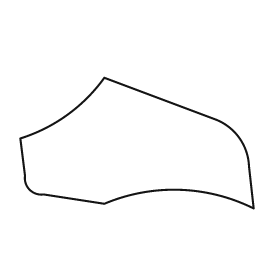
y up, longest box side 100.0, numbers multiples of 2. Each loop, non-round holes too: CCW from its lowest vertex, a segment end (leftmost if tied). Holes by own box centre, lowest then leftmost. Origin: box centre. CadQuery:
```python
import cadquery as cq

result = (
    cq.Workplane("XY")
    .moveTo(50.0, -28.0)
    .lineTo(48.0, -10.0)
    .threePointArc((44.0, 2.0), (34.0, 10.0))
    .lineTo(-14.0, 28.0)
    .threePointArc((-30.0, 12.0), (-50.0, 2.0))
    .lineTo(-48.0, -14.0)
    .threePointArc((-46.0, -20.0), (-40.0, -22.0))
    .lineTo(-14.0, -26.0)
    .threePointArc((18.0, -20.0), (50.0, -28.0))
    .close()
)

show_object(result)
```